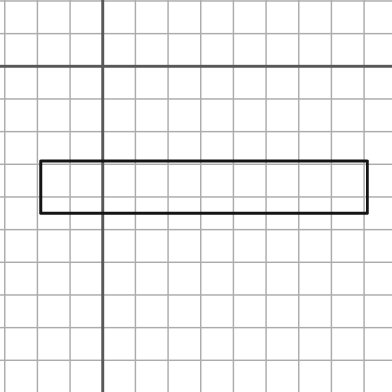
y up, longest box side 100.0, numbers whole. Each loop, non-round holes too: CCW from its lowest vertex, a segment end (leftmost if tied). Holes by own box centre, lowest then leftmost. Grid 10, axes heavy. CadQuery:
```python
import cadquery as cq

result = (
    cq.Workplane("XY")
    .moveTo(-19.0, -45.0)
    .lineTo(81.0, -45.0)
    .lineTo(81.0, -29.0)
    .lineTo(-19.0, -29.0)
    .close()
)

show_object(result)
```